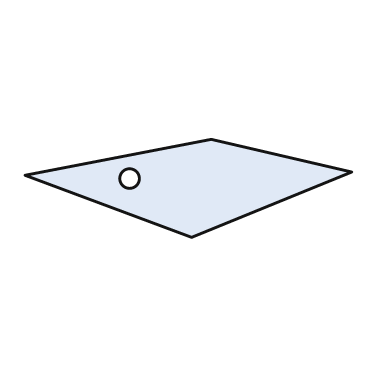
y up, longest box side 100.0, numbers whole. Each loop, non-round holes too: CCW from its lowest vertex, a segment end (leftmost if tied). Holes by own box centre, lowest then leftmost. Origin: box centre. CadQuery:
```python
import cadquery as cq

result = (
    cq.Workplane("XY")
    .moveTo(1.0, -15.0)
    .lineTo(50.0, 5.0)
    .lineTo(7.0, 15.0)
    .lineTo(-50.0, 4.0)
    .close()
    .moveTo(-18.0, 3.0)
    .circle(3.0)
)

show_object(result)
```